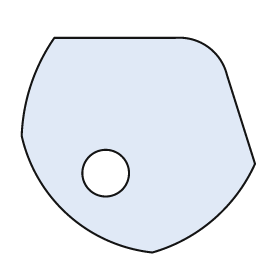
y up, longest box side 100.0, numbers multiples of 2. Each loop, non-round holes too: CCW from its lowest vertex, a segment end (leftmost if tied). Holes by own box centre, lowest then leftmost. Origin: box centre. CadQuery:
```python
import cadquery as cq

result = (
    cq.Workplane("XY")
    .moveTo(6.0, -46.0)
    .threePointArc((32.0, -32.0), (50.0, -8.0))
    .lineTo(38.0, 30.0)
    .threePointArc((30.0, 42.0), (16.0, 46.0))
    .lineTo(-36.0, 46.0)
    .threePointArc((-46.0, 26.0), (-50.0, 4.0))
    .threePointArc((-30.0, -30.0), (6.0, -46.0))
    .close()
    .moveTo(-14.0, -12.0)
    .circle(10.0)
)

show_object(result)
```